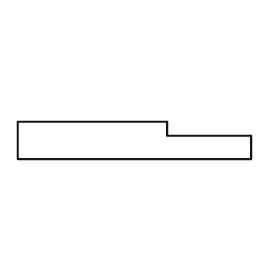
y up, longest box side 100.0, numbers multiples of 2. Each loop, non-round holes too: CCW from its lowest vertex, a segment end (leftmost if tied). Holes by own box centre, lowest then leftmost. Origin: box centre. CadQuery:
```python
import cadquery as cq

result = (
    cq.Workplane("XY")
    .moveTo(-50.0, -8.0)
    .lineTo(50.0, -8.0)
    .lineTo(50.0, 2.0)
    .lineTo(14.0, 2.0)
    .lineTo(14.0, 8.0)
    .lineTo(-50.0, 8.0)
    .close()
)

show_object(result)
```